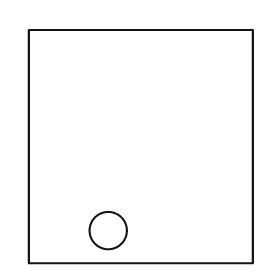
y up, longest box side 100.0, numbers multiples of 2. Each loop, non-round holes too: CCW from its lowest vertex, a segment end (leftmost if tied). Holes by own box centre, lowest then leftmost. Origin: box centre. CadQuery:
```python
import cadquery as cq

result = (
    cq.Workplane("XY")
    .moveTo(-48.0, -50.0)
    .lineTo(48.0, -50.0)
    .lineTo(48.0, 50.0)
    .lineTo(-48.0, 50.0)
    .close()
    .moveTo(-14.0, -36.0)
    .circle(8.0)
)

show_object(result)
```